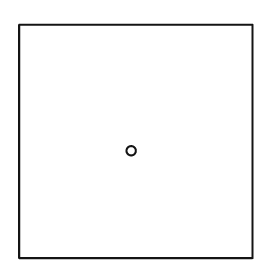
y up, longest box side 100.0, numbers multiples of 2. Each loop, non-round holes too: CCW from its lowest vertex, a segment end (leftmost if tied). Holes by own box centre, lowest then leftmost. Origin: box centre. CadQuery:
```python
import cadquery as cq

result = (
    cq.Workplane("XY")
    .moveTo(-50.0, -50.0)
    .lineTo(50.0, -50.0)
    .lineTo(50.0, 50.0)
    .lineTo(-50.0, 50.0)
    .close()
    .moveTo(-2.0, -4.0)
    .circle(2.0)
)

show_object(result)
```